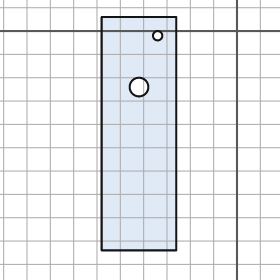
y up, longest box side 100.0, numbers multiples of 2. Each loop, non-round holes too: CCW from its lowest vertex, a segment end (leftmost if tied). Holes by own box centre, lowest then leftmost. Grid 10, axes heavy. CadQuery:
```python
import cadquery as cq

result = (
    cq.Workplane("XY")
    .moveTo(-58.0, -94.0)
    .lineTo(-26.0, -94.0)
    .lineTo(-26.0, 6.0)
    .lineTo(-58.0, 6.0)
    .close()
    .moveTo(-42.0, -24.0)
    .circle(4.0)
    .moveTo(-34.0, -2.0)
    .circle(2.0)
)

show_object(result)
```